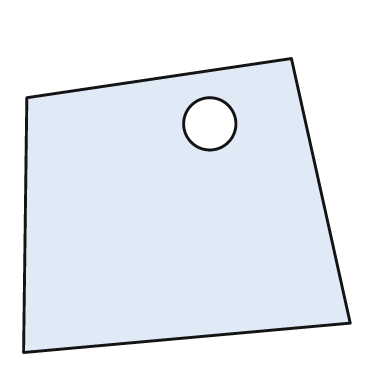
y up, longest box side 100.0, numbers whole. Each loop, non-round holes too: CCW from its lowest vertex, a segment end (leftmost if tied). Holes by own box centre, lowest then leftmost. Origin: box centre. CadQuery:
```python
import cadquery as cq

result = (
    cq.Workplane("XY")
    .moveTo(-50.0, -45.0)
    .lineTo(50.0, -36.0)
    .lineTo(32.0, 45.0)
    .lineTo(-49.0, 33.0)
    .close()
    .moveTo(7.0, 25.0)
    .circle(8.0)
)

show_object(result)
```